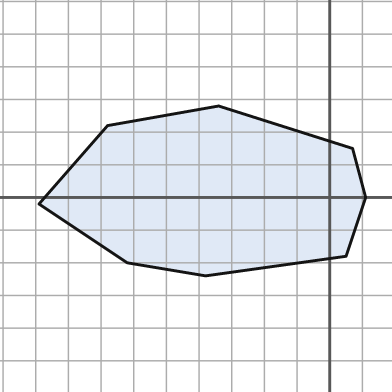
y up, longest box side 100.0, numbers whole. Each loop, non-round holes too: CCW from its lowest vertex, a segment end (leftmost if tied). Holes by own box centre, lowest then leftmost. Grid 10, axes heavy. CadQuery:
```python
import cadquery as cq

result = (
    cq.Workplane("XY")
    .moveTo(-38.0, -24.0)
    .lineTo(5.0, -18.0)
    .lineTo(11.0, 0.0)
    .lineTo(7.0, 15.0)
    .lineTo(-34.0, 28.0)
    .lineTo(-68.0, 22.0)
    .lineTo(-89.0, -2.0)
    .lineTo(-62.0, -20.0)
    .close()
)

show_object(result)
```